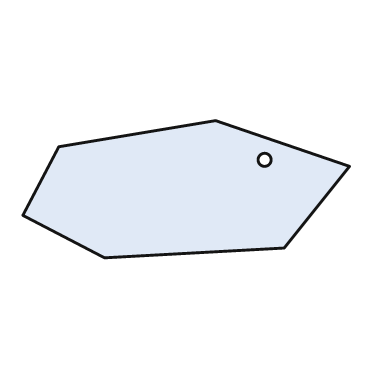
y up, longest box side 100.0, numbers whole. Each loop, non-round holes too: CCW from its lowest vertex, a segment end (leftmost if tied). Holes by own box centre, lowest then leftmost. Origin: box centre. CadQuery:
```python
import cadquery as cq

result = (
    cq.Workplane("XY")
    .moveTo(-25.0, -21.0)
    .lineTo(30.0, -18.0)
    .lineTo(50.0, 7.0)
    .lineTo(9.0, 21.0)
    .lineTo(-39.0, 13.0)
    .lineTo(-50.0, -8.0)
    .close()
    .moveTo(24.0, 9.0)
    .circle(2.0)
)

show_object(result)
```